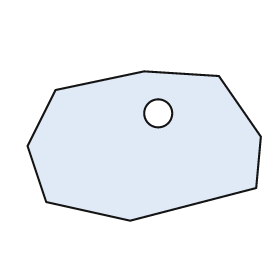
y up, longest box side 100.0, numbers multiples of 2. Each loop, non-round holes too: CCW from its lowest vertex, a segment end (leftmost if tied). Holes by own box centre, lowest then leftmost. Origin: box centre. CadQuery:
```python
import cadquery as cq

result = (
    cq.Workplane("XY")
    .moveTo(-6.0, -32.0)
    .lineTo(48.0, -18.0)
    .lineTo(50.0, 4.0)
    .lineTo(32.0, 30.0)
    .lineTo(0.0, 32.0)
    .lineTo(-38.0, 24.0)
    .lineTo(-50.0, 0.0)
    .lineTo(-42.0, -24.0)
    .close()
    .moveTo(6.0, 14.0)
    .circle(6.0)
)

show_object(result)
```